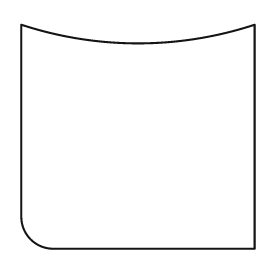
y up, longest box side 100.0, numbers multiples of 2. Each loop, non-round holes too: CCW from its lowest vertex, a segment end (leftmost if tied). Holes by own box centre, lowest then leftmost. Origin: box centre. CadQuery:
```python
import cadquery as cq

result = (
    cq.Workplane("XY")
    .moveTo(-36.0, -48.0)
    .lineTo(50.0, -48.0)
    .lineTo(50.0, 48.0)
    .threePointArc((0.0, 40.0), (-50.0, 48.0))
    .lineTo(-50.0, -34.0)
    .threePointArc((-46.0, -44.0), (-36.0, -48.0))
    .close()
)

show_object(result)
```